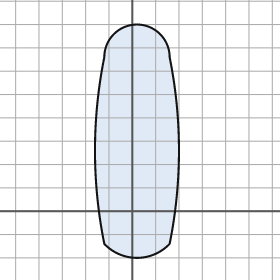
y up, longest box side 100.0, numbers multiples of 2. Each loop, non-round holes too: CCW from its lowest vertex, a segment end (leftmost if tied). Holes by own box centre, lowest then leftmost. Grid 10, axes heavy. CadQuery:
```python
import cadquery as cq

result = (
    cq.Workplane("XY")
    .moveTo(-12.0, -14.0)
    .threePointArc((2.0, -20.0), (16.0, -14.0))
    .threePointArc((20.0, 26.0), (16.0, 66.0))
    .threePointArc((2.0, 80.0), (-12.0, 66.0))
    .threePointArc((-16.0, 26.0), (-12.0, -14.0))
    .close()
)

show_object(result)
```